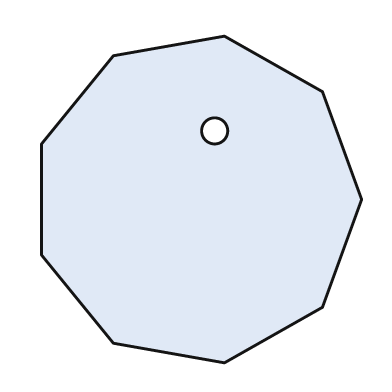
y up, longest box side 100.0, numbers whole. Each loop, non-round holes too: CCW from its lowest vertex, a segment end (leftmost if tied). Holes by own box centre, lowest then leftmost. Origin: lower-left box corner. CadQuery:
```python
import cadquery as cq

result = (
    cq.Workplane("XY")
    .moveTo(56.0, 0.0)
    .lineTo(86.0, 17.0)
    .lineTo(98.0, 50.0)
    .lineTo(86.0, 83.0)
    .lineTo(56.0, 100.0)
    .lineTo(22.0, 94.0)
    .lineTo(0.0, 67.0)
    .lineTo(0.0, 33.0)
    .lineTo(22.0, 6.0)
    .close()
    .moveTo(53.0, 71.0)
    .circle(4.0)
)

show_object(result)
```